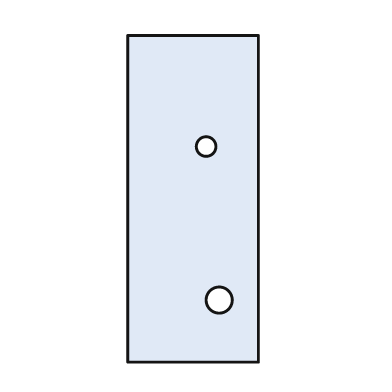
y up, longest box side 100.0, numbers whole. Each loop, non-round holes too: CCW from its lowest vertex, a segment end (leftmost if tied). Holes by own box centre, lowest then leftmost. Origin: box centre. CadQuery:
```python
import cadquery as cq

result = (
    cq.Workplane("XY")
    .moveTo(-20.0, -50.0)
    .lineTo(20.0, -50.0)
    .lineTo(20.0, 50.0)
    .lineTo(-20.0, 50.0)
    .close()
    .moveTo(8.0, -31.0)
    .circle(4.0)
    .moveTo(4.0, 16.0)
    .circle(3.0)
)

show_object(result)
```